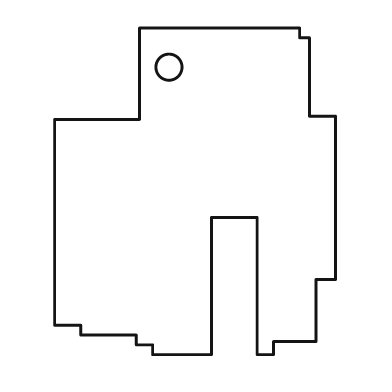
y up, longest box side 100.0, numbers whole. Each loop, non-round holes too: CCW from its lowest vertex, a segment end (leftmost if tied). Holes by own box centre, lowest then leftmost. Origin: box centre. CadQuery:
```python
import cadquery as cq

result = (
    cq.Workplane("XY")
    .moveTo(-13.0, -50.0)
    .lineTo(5.0, -50.0)
    .lineTo(5.0, -8.0)
    .lineTo(19.0, -8.0)
    .lineTo(19.0, -50.0)
    .lineTo(24.0, -50.0)
    .lineTo(24.0, -46.0)
    .lineTo(37.0, -46.0)
    .lineTo(37.0, -27.0)
    .lineTo(43.0, -27.0)
    .lineTo(43.0, 23.0)
    .lineTo(35.0, 23.0)
    .lineTo(35.0, 47.0)
    .lineTo(32.0, 47.0)
    .lineTo(32.0, 50.0)
    .lineTo(-17.0, 50.0)
    .lineTo(-17.0, 22.0)
    .lineTo(-43.0, 22.0)
    .lineTo(-43.0, -41.0)
    .lineTo(-35.0, -41.0)
    .lineTo(-35.0, -44.0)
    .lineTo(-18.0, -44.0)
    .lineTo(-18.0, -47.0)
    .lineTo(-13.0, -47.0)
    .close()
    .moveTo(-8.0, 38.0)
    .circle(4.0)
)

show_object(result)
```